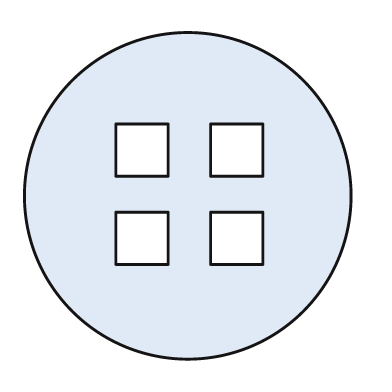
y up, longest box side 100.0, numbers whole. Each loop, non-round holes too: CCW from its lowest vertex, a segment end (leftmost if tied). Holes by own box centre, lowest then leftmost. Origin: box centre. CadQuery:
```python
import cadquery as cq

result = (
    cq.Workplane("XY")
    .moveTo(0.0, 0.0)
    .circle(50.0)
    .moveTo(-22.0, -21.0)
    .lineTo(-6.0, -21.0)
    .lineTo(-6.0, -5.0)
    .lineTo(-22.0, -5.0)
    .close()
    .moveTo(7.0, -21.0)
    .lineTo(23.0, -21.0)
    .lineTo(23.0, -5.0)
    .lineTo(7.0, -5.0)
    .close()
    .moveTo(-22.0, 6.0)
    .lineTo(-6.0, 6.0)
    .lineTo(-6.0, 22.0)
    .lineTo(-22.0, 22.0)
    .close()
    .moveTo(7.0, 6.0)
    .lineTo(23.0, 6.0)
    .lineTo(23.0, 22.0)
    .lineTo(7.0, 22.0)
    .close()
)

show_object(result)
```